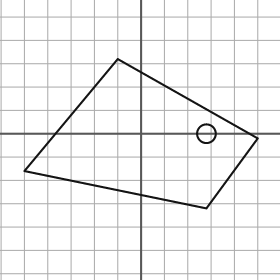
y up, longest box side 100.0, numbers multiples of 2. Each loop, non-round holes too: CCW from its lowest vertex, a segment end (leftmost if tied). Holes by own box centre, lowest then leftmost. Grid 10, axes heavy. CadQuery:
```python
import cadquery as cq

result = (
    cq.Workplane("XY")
    .moveTo(28.0, -32.0)
    .lineTo(50.0, -2.0)
    .lineTo(-10.0, 32.0)
    .lineTo(-50.0, -16.0)
    .close()
    .moveTo(28.0, 0.0)
    .circle(4.0)
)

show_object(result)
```